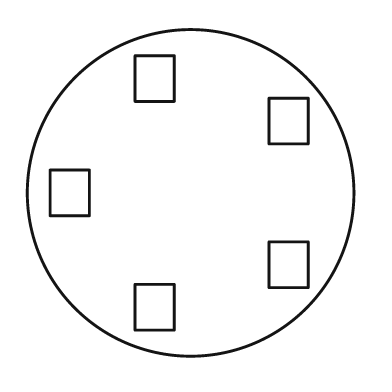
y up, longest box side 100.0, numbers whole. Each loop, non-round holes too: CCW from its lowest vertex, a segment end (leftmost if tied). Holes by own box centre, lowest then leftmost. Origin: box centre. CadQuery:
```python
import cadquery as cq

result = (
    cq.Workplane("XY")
    .moveTo(0.0, 0.0)
    .circle(50.0)
    .moveTo(-17.0, -42.0)
    .lineTo(-5.0, -42.0)
    .lineTo(-5.0, -28.0)
    .lineTo(-17.0, -28.0)
    .close()
    .moveTo(24.0, -29.0)
    .lineTo(36.0, -29.0)
    .lineTo(36.0, -15.0)
    .lineTo(24.0, -15.0)
    .close()
    .moveTo(-43.0, -7.0)
    .lineTo(-31.0, -7.0)
    .lineTo(-31.0, 7.0)
    .lineTo(-43.0, 7.0)
    .close()
    .moveTo(24.0, 15.0)
    .lineTo(36.0, 15.0)
    .lineTo(36.0, 29.0)
    .lineTo(24.0, 29.0)
    .close()
    .moveTo(-17.0, 28.0)
    .lineTo(-5.0, 28.0)
    .lineTo(-5.0, 42.0)
    .lineTo(-17.0, 42.0)
    .close()
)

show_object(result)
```